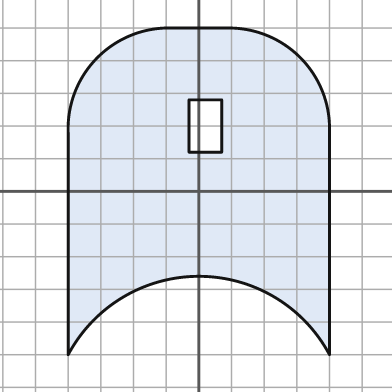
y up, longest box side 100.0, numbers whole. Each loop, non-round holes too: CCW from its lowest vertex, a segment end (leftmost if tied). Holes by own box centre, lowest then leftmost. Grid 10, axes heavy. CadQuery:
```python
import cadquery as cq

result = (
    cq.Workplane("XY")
    .moveTo(-40.0, -50.0)
    .threePointArc((0.0, -26.0), (40.0, -50.0))
    .lineTo(40.0, 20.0)
    .threePointArc((31.0, 41.0), (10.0, 50.0))
    .lineTo(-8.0, 50.0)
    .threePointArc((-31.0, 41.0), (-40.0, 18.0))
    .close()
    .moveTo(-3.0, 12.0)
    .lineTo(7.0, 12.0)
    .lineTo(7.0, 28.0)
    .lineTo(-3.0, 28.0)
    .close()
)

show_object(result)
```